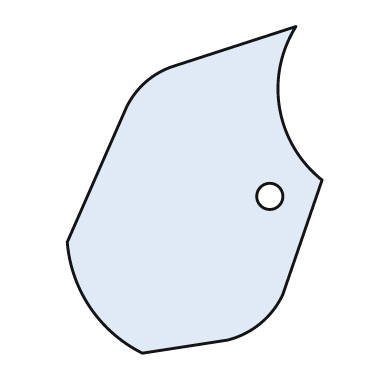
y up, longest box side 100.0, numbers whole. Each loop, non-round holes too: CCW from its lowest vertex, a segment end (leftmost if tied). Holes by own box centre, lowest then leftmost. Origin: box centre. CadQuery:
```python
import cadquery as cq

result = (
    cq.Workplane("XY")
    .moveTo(-16.0, -50.0)
    .lineTo(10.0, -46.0)
    .threePointArc((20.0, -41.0), (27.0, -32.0))
    .lineTo(39.0, 3.0)
    .threePointArc((26.0, 25.0), (31.0, 50.0))
    .lineTo(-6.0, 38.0)
    .threePointArc((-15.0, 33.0), (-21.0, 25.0))
    .lineTo(-39.0, -16.0)
    .threePointArc((-32.0, -36.0), (-16.0, -50.0))
    .close()
    .moveTo(23.0, -2.0)
    .circle(4.0)
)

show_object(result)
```